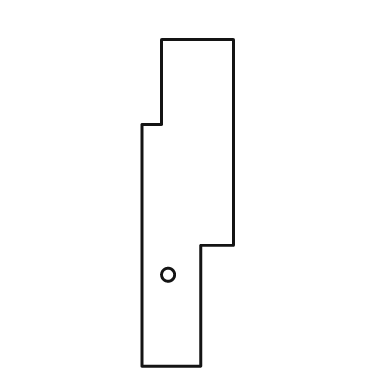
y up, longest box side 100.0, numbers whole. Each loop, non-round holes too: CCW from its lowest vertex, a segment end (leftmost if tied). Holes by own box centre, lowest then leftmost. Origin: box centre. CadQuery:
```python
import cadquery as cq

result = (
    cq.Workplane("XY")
    .moveTo(-14.0, -50.0)
    .lineTo(4.0, -50.0)
    .lineTo(4.0, -13.0)
    .lineTo(14.0, -13.0)
    .lineTo(14.0, 50.0)
    .lineTo(-8.0, 50.0)
    .lineTo(-8.0, 24.0)
    .lineTo(-14.0, 24.0)
    .close()
    .moveTo(-6.0, -22.0)
    .circle(2.0)
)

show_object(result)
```